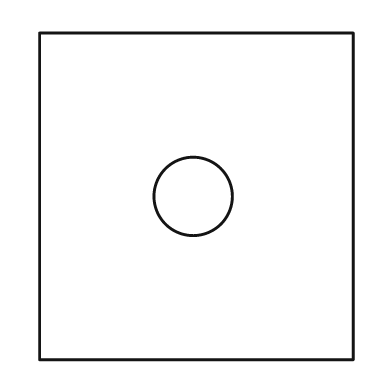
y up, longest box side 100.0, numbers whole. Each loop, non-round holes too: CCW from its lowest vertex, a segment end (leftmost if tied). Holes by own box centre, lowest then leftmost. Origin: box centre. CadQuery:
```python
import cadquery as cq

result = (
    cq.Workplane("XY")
    .moveTo(-48.0, -50.0)
    .lineTo(48.0, -50.0)
    .lineTo(48.0, 50.0)
    .lineTo(-48.0, 50.0)
    .close()
    .moveTo(-1.0, 0.0)
    .circle(12.0)
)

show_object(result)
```